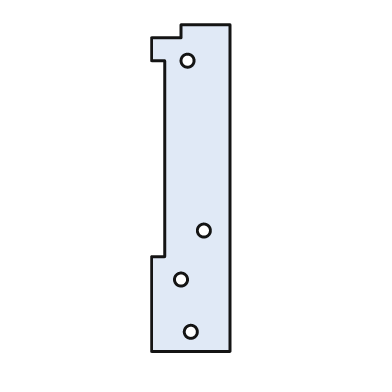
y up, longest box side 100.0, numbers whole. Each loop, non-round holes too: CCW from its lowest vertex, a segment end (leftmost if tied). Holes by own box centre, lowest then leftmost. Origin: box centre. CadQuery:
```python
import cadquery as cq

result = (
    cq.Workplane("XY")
    .moveTo(-12.0, -50.0)
    .lineTo(12.0, -50.0)
    .lineTo(12.0, 50.0)
    .lineTo(-3.0, 50.0)
    .lineTo(-3.0, 46.0)
    .lineTo(-12.0, 46.0)
    .lineTo(-12.0, 39.0)
    .lineTo(-8.0, 39.0)
    .lineTo(-8.0, -21.0)
    .lineTo(-12.0, -21.0)
    .close()
    .moveTo(0.0, -44.0)
    .circle(2.0)
    .moveTo(-3.0, -28.0)
    .circle(2.0)
    .moveTo(4.0, -13.0)
    .circle(2.0)
    .moveTo(-1.0, 39.0)
    .circle(2.0)
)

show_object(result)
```